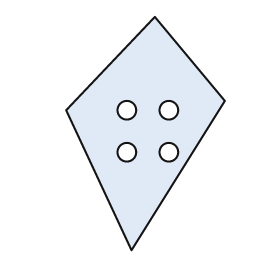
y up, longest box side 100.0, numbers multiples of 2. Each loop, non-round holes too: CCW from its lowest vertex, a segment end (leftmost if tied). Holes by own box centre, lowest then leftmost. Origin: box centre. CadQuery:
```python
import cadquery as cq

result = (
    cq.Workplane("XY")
    .moveTo(-6.0, -50.0)
    .lineTo(34.0, 14.0)
    .lineTo(4.0, 50.0)
    .lineTo(-34.0, 10.0)
    .close()
    .moveTo(-8.0, -8.0)
    .circle(4.0)
    .moveTo(10.0, -8.0)
    .circle(4.0)
    .moveTo(-8.0, 10.0)
    .circle(4.0)
    .moveTo(10.0, 10.0)
    .circle(4.0)
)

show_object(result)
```